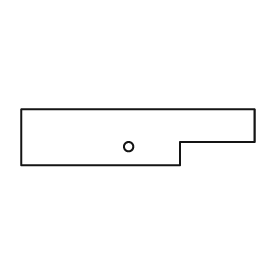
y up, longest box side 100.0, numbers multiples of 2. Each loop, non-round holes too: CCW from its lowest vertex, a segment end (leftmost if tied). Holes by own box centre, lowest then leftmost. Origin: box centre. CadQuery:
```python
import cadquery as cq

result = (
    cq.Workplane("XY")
    .moveTo(-50.0, -12.0)
    .lineTo(18.0, -12.0)
    .lineTo(18.0, -2.0)
    .lineTo(50.0, -2.0)
    .lineTo(50.0, 12.0)
    .lineTo(-50.0, 12.0)
    .close()
    .moveTo(-4.0, -4.0)
    .circle(2.0)
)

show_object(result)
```